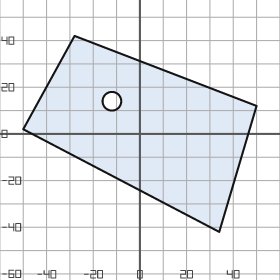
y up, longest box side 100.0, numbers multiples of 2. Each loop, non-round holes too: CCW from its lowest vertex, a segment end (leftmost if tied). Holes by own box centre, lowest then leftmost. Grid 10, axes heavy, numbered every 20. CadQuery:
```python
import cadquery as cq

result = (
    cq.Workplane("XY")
    .moveTo(34.0, -42.0)
    .lineTo(50.0, 12.0)
    .lineTo(-28.0, 42.0)
    .lineTo(-50.0, 2.0)
    .close()
    .moveTo(-12.0, 14.0)
    .circle(4.0)
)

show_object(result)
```